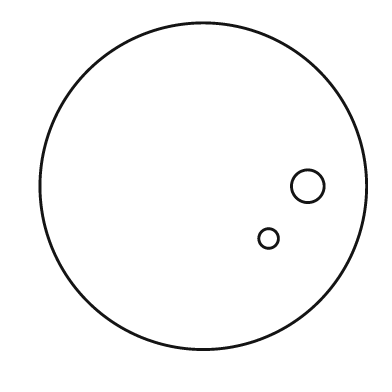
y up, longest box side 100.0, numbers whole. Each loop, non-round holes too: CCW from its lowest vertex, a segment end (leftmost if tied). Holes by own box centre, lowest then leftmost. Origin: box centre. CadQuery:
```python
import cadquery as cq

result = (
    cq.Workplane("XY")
    .moveTo(0.0, 0.0)
    .circle(50.0)
    .moveTo(20.0, -16.0)
    .circle(3.0)
    .moveTo(32.0, 0.0)
    .circle(5.0)
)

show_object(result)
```